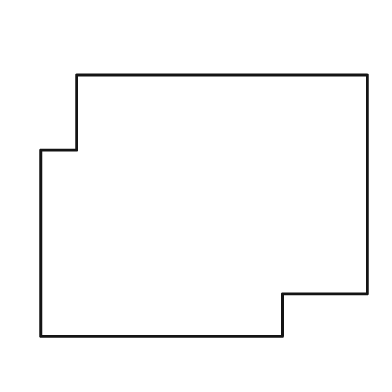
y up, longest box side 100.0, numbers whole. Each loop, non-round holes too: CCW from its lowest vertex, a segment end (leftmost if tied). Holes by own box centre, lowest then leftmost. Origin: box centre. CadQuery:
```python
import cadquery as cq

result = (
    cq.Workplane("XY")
    .moveTo(-50.0, -40.0)
    .lineTo(24.0, -40.0)
    .lineTo(24.0, -27.0)
    .lineTo(50.0, -27.0)
    .lineTo(50.0, 40.0)
    .lineTo(-39.0, 40.0)
    .lineTo(-39.0, 17.0)
    .lineTo(-50.0, 17.0)
    .close()
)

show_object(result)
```